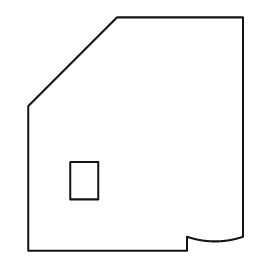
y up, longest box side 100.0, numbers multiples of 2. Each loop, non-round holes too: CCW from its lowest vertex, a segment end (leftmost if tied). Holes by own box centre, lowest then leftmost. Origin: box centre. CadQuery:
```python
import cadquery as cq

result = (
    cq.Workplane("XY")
    .moveTo(-46.0, -50.0)
    .lineTo(22.0, -50.0)
    .lineTo(22.0, -44.0)
    .threePointArc((34.0, -46.0), (46.0, -44.0))
    .lineTo(46.0, 50.0)
    .lineTo(-8.0, 50.0)
    .lineTo(-46.0, 12.0)
    .close()
    .moveTo(-28.0, -28.0)
    .lineTo(-16.0, -28.0)
    .lineTo(-16.0, -12.0)
    .lineTo(-28.0, -12.0)
    .close()
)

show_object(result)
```